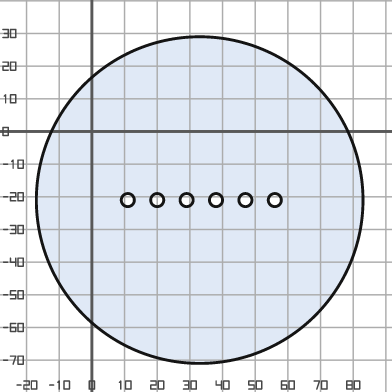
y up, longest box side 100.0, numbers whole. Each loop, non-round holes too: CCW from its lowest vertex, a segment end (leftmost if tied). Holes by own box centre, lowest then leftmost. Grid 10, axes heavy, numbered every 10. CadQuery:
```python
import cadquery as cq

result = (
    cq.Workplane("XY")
    .moveTo(33.0, -21.0)
    .circle(50.0)
    .moveTo(11.0, -21.0)
    .circle(2.0)
    .moveTo(20.0, -21.0)
    .circle(2.0)
    .moveTo(29.0, -21.0)
    .circle(2.0)
    .moveTo(38.0, -21.0)
    .circle(2.0)
    .moveTo(47.0, -21.0)
    .circle(2.0)
    .moveTo(56.0, -21.0)
    .circle(2.0)
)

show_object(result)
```